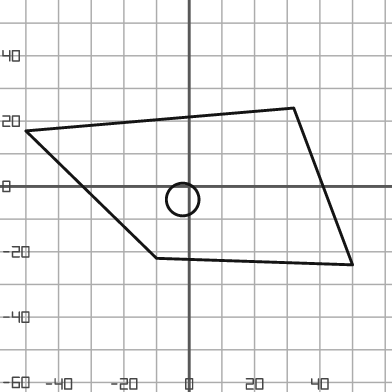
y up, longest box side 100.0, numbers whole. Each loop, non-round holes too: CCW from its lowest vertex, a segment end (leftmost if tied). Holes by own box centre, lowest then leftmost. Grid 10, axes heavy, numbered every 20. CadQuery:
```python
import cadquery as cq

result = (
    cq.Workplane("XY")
    .moveTo(50.0, -24.0)
    .lineTo(32.0, 24.0)
    .lineTo(-50.0, 17.0)
    .lineTo(-10.0, -22.0)
    .close()
    .moveTo(-2.0, -4.0)
    .circle(5.0)
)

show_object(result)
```